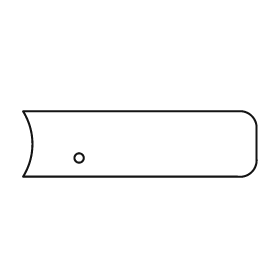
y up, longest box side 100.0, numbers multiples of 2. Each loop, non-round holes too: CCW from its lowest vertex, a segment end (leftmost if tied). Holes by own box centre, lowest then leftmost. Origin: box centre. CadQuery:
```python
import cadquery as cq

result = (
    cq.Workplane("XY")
    .moveTo(-50.0, -14.0)
    .lineTo(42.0, -14.0)
    .threePointArc((48.0, -12.0), (50.0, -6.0))
    .lineTo(50.0, 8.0)
    .threePointArc((48.0, 12.0), (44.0, 14.0))
    .lineTo(-50.0, 14.0)
    .threePointArc((-46.0, 0.0), (-50.0, -14.0))
    .close()
    .moveTo(-26.0, -6.0)
    .circle(2.0)
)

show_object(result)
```